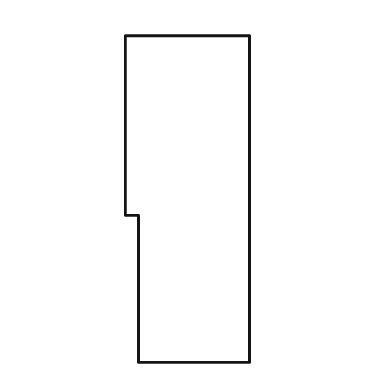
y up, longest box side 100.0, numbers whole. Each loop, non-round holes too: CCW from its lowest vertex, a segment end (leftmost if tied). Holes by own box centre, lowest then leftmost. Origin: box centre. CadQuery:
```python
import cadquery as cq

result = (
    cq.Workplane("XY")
    .moveTo(-15.0, -50.0)
    .lineTo(19.0, -50.0)
    .lineTo(19.0, 50.0)
    .lineTo(-19.0, 50.0)
    .lineTo(-19.0, -5.0)
    .lineTo(-15.0, -5.0)
    .close()
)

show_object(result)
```